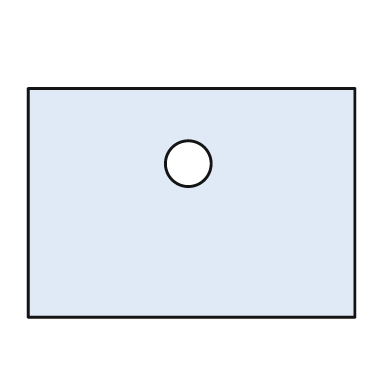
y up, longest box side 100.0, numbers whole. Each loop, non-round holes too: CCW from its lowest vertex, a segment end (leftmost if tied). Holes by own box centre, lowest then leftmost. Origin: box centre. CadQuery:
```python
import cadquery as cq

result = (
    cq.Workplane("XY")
    .moveTo(-50.0, -35.0)
    .lineTo(50.0, -35.0)
    .lineTo(50.0, 35.0)
    .lineTo(-50.0, 35.0)
    .close()
    .moveTo(-1.0, 12.0)
    .circle(7.0)
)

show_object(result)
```